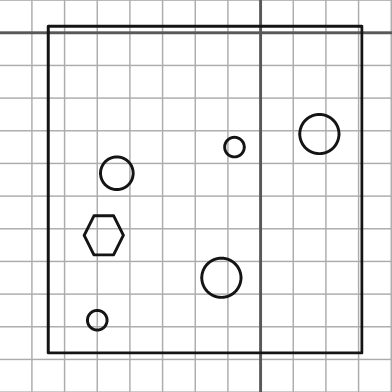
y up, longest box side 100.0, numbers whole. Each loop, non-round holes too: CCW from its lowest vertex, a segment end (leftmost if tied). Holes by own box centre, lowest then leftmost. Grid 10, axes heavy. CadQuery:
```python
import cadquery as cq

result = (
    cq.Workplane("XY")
    .moveTo(-65.0, -98.0)
    .lineTo(31.0, -98.0)
    .lineTo(31.0, 2.0)
    .lineTo(-65.0, 2.0)
    .close()
    .moveTo(-50.0, -88.0)
    .circle(3.0)
    .moveTo(-12.0, -75.0)
    .circle(6.0)
    .moveTo(-51.0, -68.0)
    .lineTo(-45.0, -68.0)
    .lineTo(-42.0, -62.0)
    .lineTo(-45.0, -56.0)
    .lineTo(-51.0, -56.0)
    .lineTo(-54.0, -62.0)
    .close()
    .moveTo(-44.0, -43.0)
    .circle(5.0)
    .moveTo(-8.0, -35.0)
    .circle(3.0)
    .moveTo(18.0, -31.0)
    .circle(6.0)
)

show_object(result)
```